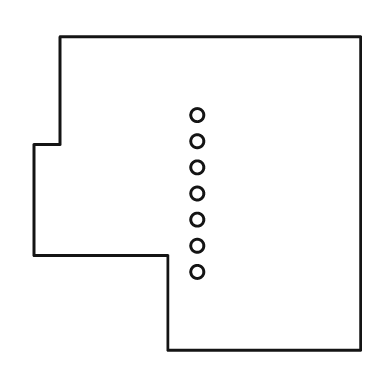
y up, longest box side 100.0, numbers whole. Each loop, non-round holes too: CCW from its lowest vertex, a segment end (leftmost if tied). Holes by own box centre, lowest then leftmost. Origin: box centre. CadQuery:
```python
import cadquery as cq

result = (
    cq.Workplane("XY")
    .moveTo(-9.0, -48.0)
    .lineTo(50.0, -48.0)
    .lineTo(50.0, 48.0)
    .lineTo(-42.0, 48.0)
    .lineTo(-42.0, 15.0)
    .lineTo(-50.0, 15.0)
    .lineTo(-50.0, -19.0)
    .lineTo(-9.0, -19.0)
    .close()
    .moveTo(0.0, -24.0)
    .circle(2.0)
    .moveTo(0.0, -16.0)
    .circle(2.0)
    .moveTo(0.0, -8.0)
    .circle(2.0)
    .moveTo(0.0, 0.0)
    .circle(2.0)
    .moveTo(0.0, 8.0)
    .circle(2.0)
    .moveTo(0.0, 16.0)
    .circle(2.0)
    .moveTo(0.0, 24.0)
    .circle(2.0)
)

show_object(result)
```